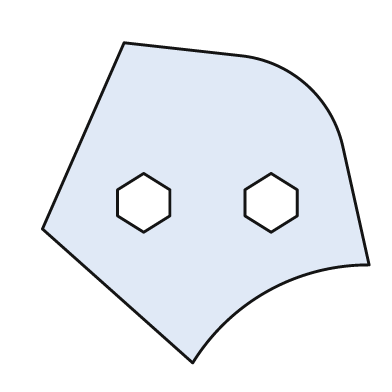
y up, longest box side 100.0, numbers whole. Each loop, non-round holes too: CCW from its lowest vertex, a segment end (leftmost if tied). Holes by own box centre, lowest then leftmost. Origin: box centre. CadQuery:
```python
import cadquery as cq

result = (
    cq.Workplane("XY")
    .moveTo(-4.0, -49.0)
    .threePointArc((19.0, -27.0), (50.0, -19.0))
    .lineTo(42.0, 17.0)
    .threePointArc((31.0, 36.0), (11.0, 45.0))
    .lineTo(-25.0, 49.0)
    .lineTo(-50.0, -8.0)
    .close()
    .moveTo(-19.0, -9.0)
    .lineTo(-11.0, -4.0)
    .lineTo(-11.0, 4.0)
    .lineTo(-19.0, 9.0)
    .lineTo(-27.0, 4.0)
    .lineTo(-27.0, -4.0)
    .close()
    .moveTo(20.0, -9.0)
    .lineTo(28.0, -4.0)
    .lineTo(28.0, 4.0)
    .lineTo(20.0, 9.0)
    .lineTo(12.0, 4.0)
    .lineTo(12.0, -4.0)
    .close()
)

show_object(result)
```